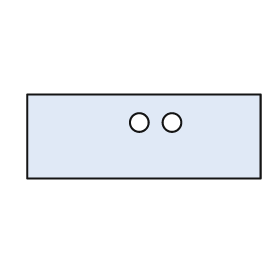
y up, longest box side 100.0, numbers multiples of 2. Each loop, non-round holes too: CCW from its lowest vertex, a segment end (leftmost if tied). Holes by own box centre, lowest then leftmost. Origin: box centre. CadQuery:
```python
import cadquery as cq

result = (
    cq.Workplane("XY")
    .moveTo(-50.0, -18.0)
    .lineTo(50.0, -18.0)
    .lineTo(50.0, 18.0)
    .lineTo(-50.0, 18.0)
    .close()
    .moveTo(-2.0, 6.0)
    .circle(4.0)
    .moveTo(12.0, 6.0)
    .circle(4.0)
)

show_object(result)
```